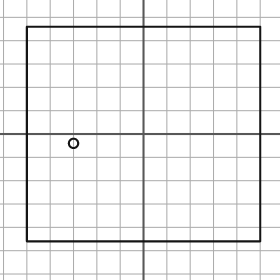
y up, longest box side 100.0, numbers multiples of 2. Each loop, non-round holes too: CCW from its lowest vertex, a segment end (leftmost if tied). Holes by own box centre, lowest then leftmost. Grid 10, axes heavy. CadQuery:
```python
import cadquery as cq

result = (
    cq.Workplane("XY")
    .moveTo(-50.0, -46.0)
    .lineTo(50.0, -46.0)
    .lineTo(50.0, 46.0)
    .lineTo(-50.0, 46.0)
    .close()
    .moveTo(-30.0, -4.0)
    .circle(2.0)
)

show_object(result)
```